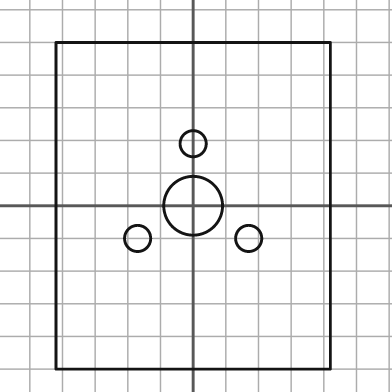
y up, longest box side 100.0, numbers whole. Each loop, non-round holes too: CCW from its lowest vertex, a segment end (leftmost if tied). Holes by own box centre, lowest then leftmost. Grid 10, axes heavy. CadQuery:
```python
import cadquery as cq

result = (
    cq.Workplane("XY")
    .moveTo(-42.0, -50.0)
    .lineTo(42.0, -50.0)
    .lineTo(42.0, 50.0)
    .lineTo(-42.0, 50.0)
    .close()
    .moveTo(-17.0, -10.0)
    .circle(4.0)
    .moveTo(17.0, -10.0)
    .circle(4.0)
    .moveTo(0.0, 0.0)
    .circle(9.0)
    .moveTo(0.0, 19.0)
    .circle(4.0)
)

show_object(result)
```